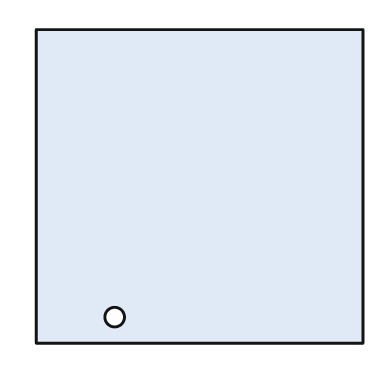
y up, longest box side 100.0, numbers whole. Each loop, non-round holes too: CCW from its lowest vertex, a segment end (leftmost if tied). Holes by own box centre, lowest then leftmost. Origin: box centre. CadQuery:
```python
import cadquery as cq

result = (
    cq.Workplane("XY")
    .moveTo(-50.0, -48.0)
    .lineTo(50.0, -48.0)
    .lineTo(50.0, 48.0)
    .lineTo(-50.0, 48.0)
    .close()
    .moveTo(-26.0, -40.0)
    .circle(3.0)
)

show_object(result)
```